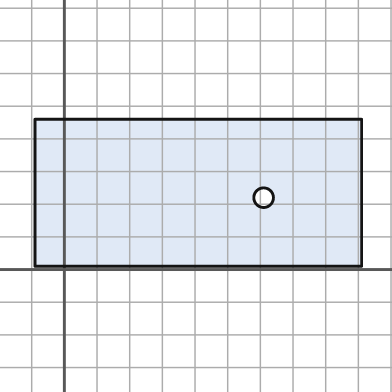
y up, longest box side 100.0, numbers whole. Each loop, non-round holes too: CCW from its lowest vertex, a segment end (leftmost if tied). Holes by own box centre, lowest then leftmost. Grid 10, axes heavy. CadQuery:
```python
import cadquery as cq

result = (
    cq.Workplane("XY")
    .moveTo(-9.0, 1.0)
    .lineTo(91.0, 1.0)
    .lineTo(91.0, 46.0)
    .lineTo(-9.0, 46.0)
    .close()
    .moveTo(61.0, 22.0)
    .circle(3.0)
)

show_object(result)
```